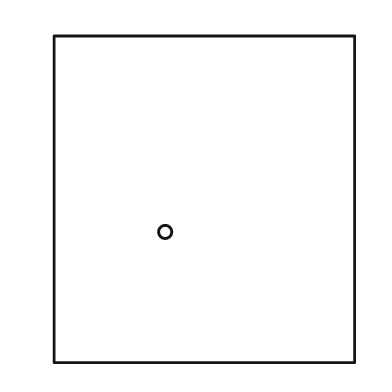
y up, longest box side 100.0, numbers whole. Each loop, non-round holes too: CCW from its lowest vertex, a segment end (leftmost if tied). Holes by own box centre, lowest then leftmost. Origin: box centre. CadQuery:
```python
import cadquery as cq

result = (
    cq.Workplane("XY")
    .moveTo(-46.0, -50.0)
    .lineTo(46.0, -50.0)
    .lineTo(46.0, 50.0)
    .lineTo(-46.0, 50.0)
    .close()
    .moveTo(-12.0, -10.0)
    .circle(2.0)
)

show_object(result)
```